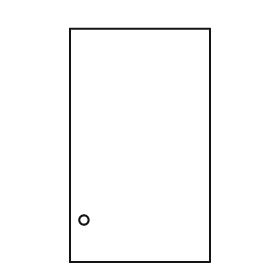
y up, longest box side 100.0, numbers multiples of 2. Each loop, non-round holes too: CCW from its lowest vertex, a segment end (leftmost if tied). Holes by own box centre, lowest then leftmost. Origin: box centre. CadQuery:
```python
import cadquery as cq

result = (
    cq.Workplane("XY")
    .moveTo(-30.0, -50.0)
    .lineTo(30.0, -50.0)
    .lineTo(30.0, 50.0)
    .lineTo(-30.0, 50.0)
    .close()
    .moveTo(-24.0, -32.0)
    .circle(2.0)
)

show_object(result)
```